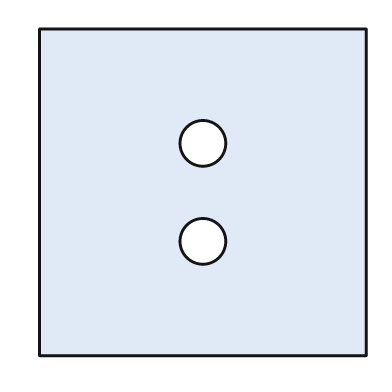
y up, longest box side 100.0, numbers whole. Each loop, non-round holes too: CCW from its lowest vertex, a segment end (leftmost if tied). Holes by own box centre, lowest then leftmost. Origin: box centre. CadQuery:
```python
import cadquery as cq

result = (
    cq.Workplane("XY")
    .moveTo(-50.0, -50.0)
    .lineTo(50.0, -50.0)
    .lineTo(50.0, 50.0)
    .lineTo(-50.0, 50.0)
    .close()
    .moveTo(0.0, -15.0)
    .circle(7.0)
    .moveTo(0.0, 15.0)
    .circle(7.0)
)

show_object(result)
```